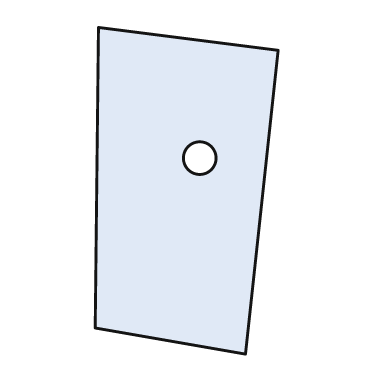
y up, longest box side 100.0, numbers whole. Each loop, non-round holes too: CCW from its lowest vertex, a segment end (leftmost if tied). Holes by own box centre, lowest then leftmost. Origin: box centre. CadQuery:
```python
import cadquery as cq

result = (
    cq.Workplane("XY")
    .moveTo(18.0, -50.0)
    .lineTo(28.0, 43.0)
    .lineTo(-27.0, 50.0)
    .lineTo(-28.0, -42.0)
    .close()
    .moveTo(4.0, 10.0)
    .circle(5.0)
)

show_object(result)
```